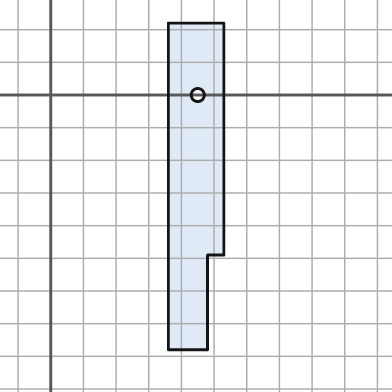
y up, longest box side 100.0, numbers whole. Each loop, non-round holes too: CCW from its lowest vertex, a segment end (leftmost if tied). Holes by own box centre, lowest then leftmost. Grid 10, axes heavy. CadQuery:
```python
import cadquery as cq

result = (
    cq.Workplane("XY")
    .moveTo(36.0, -78.0)
    .lineTo(48.0, -78.0)
    .lineTo(48.0, -49.0)
    .lineTo(53.0, -49.0)
    .lineTo(53.0, 22.0)
    .lineTo(36.0, 22.0)
    .close()
    .moveTo(45.0, 0.0)
    .circle(2.0)
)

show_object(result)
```